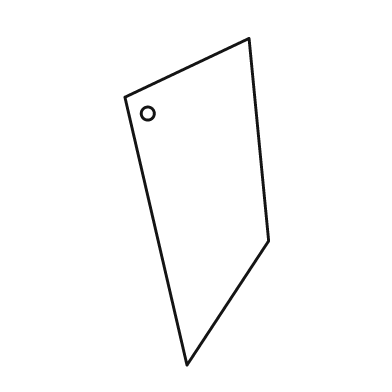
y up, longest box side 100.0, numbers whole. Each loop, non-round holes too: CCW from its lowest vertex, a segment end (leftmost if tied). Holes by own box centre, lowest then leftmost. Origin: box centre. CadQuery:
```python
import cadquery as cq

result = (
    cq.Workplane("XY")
    .moveTo(-3.0, -50.0)
    .lineTo(22.0, -12.0)
    .lineTo(16.0, 50.0)
    .lineTo(-22.0, 32.0)
    .close()
    .moveTo(-15.0, 27.0)
    .circle(2.0)
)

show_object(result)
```